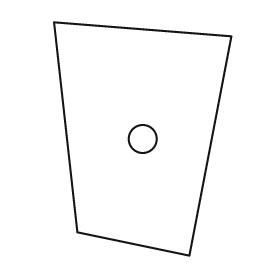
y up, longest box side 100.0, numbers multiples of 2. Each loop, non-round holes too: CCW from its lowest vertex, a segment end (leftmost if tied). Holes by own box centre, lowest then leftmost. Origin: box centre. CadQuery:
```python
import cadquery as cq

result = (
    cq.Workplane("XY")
    .moveTo(20.0, -50.0)
    .lineTo(38.0, 44.0)
    .lineTo(-38.0, 50.0)
    .lineTo(-28.0, -40.0)
    .close()
    .moveTo(0.0, 0.0)
    .circle(6.0)
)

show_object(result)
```